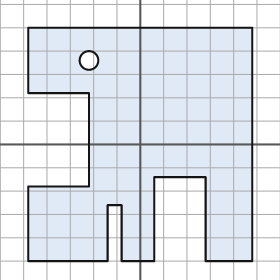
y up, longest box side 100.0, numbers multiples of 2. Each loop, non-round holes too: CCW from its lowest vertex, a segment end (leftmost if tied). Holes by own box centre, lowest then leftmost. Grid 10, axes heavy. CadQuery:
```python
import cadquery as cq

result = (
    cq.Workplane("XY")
    .moveTo(-48.0, -50.0)
    .lineTo(-14.0, -50.0)
    .lineTo(-14.0, -26.0)
    .lineTo(-8.0, -26.0)
    .lineTo(-8.0, -50.0)
    .lineTo(6.0, -50.0)
    .lineTo(6.0, -14.0)
    .lineTo(28.0, -14.0)
    .lineTo(28.0, -50.0)
    .lineTo(48.0, -50.0)
    .lineTo(48.0, 50.0)
    .lineTo(-48.0, 50.0)
    .lineTo(-48.0, 22.0)
    .lineTo(-22.0, 22.0)
    .lineTo(-22.0, -18.0)
    .lineTo(-48.0, -18.0)
    .close()
    .moveTo(-22.0, 36.0)
    .circle(4.0)
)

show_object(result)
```